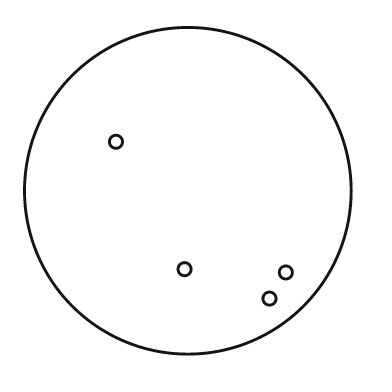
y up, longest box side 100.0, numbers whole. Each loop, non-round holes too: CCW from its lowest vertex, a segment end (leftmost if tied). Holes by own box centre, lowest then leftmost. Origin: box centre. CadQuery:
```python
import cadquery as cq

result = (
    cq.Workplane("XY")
    .moveTo(0.0, 0.0)
    .circle(50.0)
    .moveTo(25.0, -33.0)
    .circle(2.0)
    .moveTo(30.0, -25.0)
    .circle(2.0)
    .moveTo(-1.0, -24.0)
    .circle(2.0)
    .moveTo(-22.0, 15.0)
    .circle(2.0)
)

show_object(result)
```